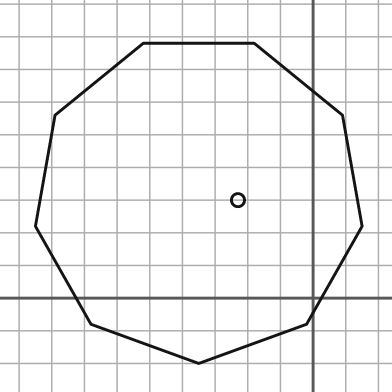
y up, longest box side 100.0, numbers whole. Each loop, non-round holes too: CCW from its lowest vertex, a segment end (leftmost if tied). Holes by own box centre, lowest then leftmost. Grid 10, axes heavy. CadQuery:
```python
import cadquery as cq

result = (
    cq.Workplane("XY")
    .moveTo(-35.0, -20.0)
    .lineTo(-2.0, -8.0)
    .lineTo(15.0, 22.0)
    .lineTo(9.0, 56.0)
    .lineTo(-18.0, 78.0)
    .lineTo(-52.0, 78.0)
    .lineTo(-79.0, 56.0)
    .lineTo(-85.0, 22.0)
    .lineTo(-68.0, -8.0)
    .close()
    .moveTo(-23.0, 30.0)
    .circle(2.0)
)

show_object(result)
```